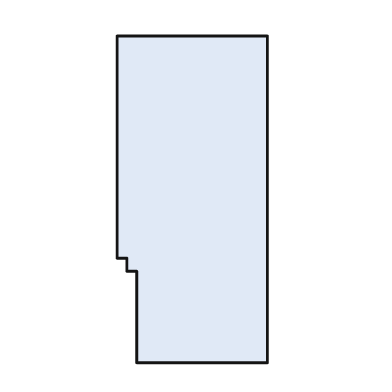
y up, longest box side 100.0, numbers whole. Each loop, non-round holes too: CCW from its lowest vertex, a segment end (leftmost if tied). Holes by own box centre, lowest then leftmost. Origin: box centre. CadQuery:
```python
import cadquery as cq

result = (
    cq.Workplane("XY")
    .moveTo(-17.0, -50.0)
    .lineTo(23.0, -50.0)
    .lineTo(23.0, 50.0)
    .lineTo(-23.0, 50.0)
    .lineTo(-23.0, -18.0)
    .lineTo(-20.0, -18.0)
    .lineTo(-20.0, -22.0)
    .lineTo(-17.0, -22.0)
    .close()
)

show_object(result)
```